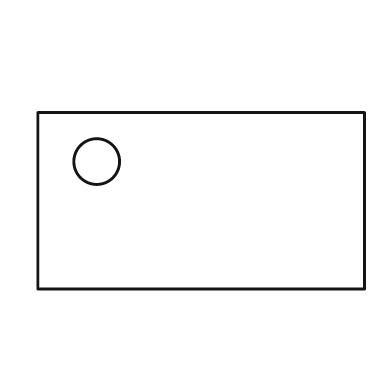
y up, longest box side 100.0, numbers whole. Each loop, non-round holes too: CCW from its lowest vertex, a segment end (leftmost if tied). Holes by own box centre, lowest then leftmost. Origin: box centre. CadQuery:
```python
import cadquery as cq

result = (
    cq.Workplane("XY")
    .moveTo(-50.0, -27.0)
    .lineTo(50.0, -27.0)
    .lineTo(50.0, 27.0)
    .lineTo(-50.0, 27.0)
    .close()
    .moveTo(-32.0, 12.0)
    .circle(7.0)
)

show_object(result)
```